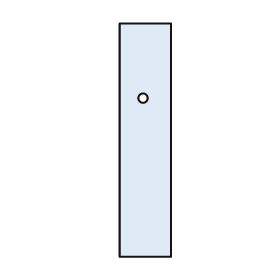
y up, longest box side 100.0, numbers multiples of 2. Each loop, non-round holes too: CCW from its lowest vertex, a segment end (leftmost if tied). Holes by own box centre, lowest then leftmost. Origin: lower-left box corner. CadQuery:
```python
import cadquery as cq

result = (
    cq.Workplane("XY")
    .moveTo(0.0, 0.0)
    .lineTo(22.0, 0.0)
    .lineTo(22.0, 100.0)
    .lineTo(0.0, 100.0)
    .close()
    .moveTo(10.0, 68.0)
    .circle(2.0)
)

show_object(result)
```